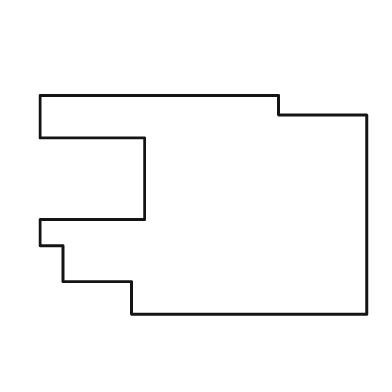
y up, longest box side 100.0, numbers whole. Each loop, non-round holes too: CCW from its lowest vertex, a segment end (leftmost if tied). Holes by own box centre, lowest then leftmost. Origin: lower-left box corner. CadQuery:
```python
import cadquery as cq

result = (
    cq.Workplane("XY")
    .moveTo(28.0, 0.0)
    .lineTo(100.0, 0.0)
    .lineTo(100.0, 61.0)
    .lineTo(73.0, 61.0)
    .lineTo(73.0, 67.0)
    .lineTo(0.0, 67.0)
    .lineTo(0.0, 54.0)
    .lineTo(32.0, 54.0)
    .lineTo(32.0, 29.0)
    .lineTo(0.0, 29.0)
    .lineTo(0.0, 21.0)
    .lineTo(7.0, 21.0)
    .lineTo(7.0, 10.0)
    .lineTo(28.0, 10.0)
    .close()
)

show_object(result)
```